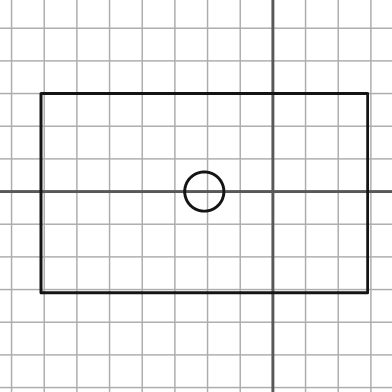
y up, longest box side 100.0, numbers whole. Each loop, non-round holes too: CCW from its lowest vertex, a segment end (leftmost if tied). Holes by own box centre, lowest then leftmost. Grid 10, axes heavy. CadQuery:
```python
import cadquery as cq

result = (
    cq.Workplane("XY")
    .moveTo(-71.0, -31.0)
    .lineTo(29.0, -31.0)
    .lineTo(29.0, 30.0)
    .lineTo(-71.0, 30.0)
    .close()
    .moveTo(-21.0, 0.0)
    .circle(6.0)
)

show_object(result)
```